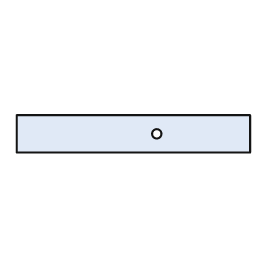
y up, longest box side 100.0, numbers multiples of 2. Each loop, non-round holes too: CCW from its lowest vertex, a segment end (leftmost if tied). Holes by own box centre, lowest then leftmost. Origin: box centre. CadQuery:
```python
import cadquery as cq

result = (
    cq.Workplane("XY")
    .moveTo(-50.0, -8.0)
    .lineTo(50.0, -8.0)
    .lineTo(50.0, 8.0)
    .lineTo(-50.0, 8.0)
    .close()
    .moveTo(10.0, 0.0)
    .circle(2.0)
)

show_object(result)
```